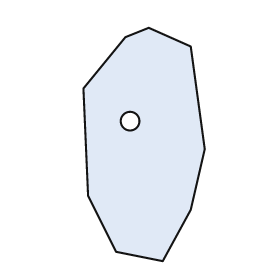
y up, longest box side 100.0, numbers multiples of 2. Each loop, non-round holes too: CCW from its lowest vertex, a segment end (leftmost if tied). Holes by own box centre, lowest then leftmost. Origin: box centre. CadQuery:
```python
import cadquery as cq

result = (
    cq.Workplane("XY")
    .moveTo(8.0, -50.0)
    .lineTo(20.0, -28.0)
    .lineTo(26.0, -2.0)
    .lineTo(20.0, 42.0)
    .lineTo(2.0, 50.0)
    .lineTo(-8.0, 46.0)
    .lineTo(-26.0, 24.0)
    .lineTo(-24.0, -22.0)
    .lineTo(-12.0, -46.0)
    .close()
    .moveTo(-6.0, 10.0)
    .circle(4.0)
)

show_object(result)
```